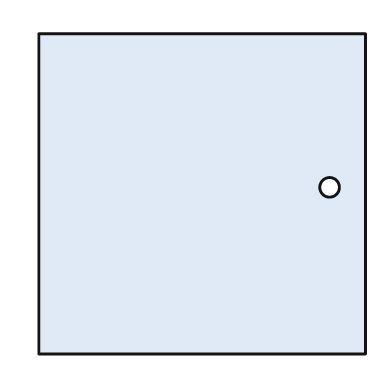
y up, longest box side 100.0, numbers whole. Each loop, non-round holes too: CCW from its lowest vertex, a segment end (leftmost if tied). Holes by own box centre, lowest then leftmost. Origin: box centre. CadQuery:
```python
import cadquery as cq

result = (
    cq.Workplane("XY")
    .moveTo(-50.0, -49.0)
    .lineTo(50.0, -49.0)
    .lineTo(50.0, 49.0)
    .lineTo(-50.0, 49.0)
    .close()
    .moveTo(39.0, 2.0)
    .circle(3.0)
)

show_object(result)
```